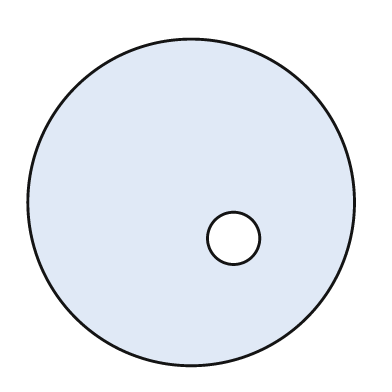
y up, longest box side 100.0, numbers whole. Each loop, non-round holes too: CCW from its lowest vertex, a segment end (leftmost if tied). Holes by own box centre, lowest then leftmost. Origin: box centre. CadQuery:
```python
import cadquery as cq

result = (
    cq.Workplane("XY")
    .moveTo(0.0, 0.0)
    .circle(50.0)
    .moveTo(13.0, -11.0)
    .circle(8.0)
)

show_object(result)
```